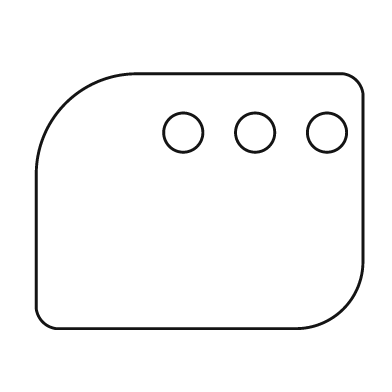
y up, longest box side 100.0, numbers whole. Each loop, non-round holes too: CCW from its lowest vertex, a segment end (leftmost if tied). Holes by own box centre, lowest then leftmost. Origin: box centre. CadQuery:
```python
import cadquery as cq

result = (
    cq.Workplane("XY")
    .moveTo(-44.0, -39.0)
    .lineTo(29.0, -39.0)
    .threePointArc((44.0, -33.0), (50.0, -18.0))
    .lineTo(50.0, 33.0)
    .threePointArc((48.0, 37.0), (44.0, 39.0))
    .lineTo(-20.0, 39.0)
    .threePointArc((-41.0, 30.0), (-50.0, 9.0))
    .lineTo(-50.0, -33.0)
    .threePointArc((-48.0, -37.0), (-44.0, -39.0))
    .close()
    .moveTo(-5.0, 21.0)
    .circle(6.0)
    .moveTo(17.0, 21.0)
    .circle(6.0)
    .moveTo(39.0, 21.0)
    .circle(6.0)
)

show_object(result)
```